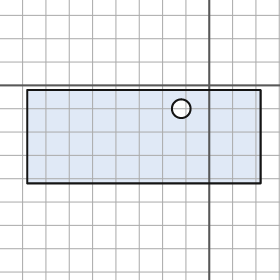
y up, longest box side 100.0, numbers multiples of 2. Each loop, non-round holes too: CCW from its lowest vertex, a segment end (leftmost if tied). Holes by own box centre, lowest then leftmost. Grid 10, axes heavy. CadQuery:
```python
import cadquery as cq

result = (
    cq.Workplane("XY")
    .moveTo(-78.0, -42.0)
    .lineTo(22.0, -42.0)
    .lineTo(22.0, -2.0)
    .lineTo(-78.0, -2.0)
    .close()
    .moveTo(-12.0, -10.0)
    .circle(4.0)
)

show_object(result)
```